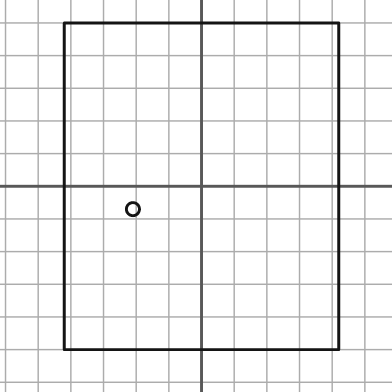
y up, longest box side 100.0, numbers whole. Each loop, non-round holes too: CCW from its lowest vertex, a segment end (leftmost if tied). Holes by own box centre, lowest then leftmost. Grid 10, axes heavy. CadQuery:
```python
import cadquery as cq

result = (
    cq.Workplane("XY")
    .moveTo(-42.0, -50.0)
    .lineTo(42.0, -50.0)
    .lineTo(42.0, 50.0)
    .lineTo(-42.0, 50.0)
    .close()
    .moveTo(-21.0, -7.0)
    .circle(2.0)
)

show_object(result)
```